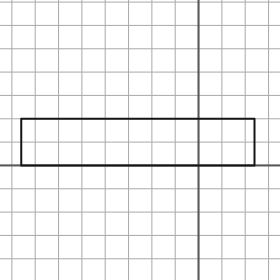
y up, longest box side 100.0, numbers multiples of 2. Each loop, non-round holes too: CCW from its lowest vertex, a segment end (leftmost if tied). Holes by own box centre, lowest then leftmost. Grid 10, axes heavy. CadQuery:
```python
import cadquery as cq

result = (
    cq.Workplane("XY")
    .moveTo(-76.0, 0.0)
    .lineTo(24.0, 0.0)
    .lineTo(24.0, 20.0)
    .lineTo(-76.0, 20.0)
    .close()
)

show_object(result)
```